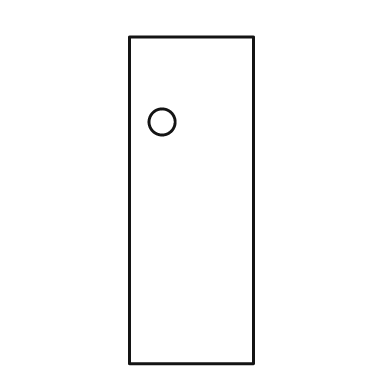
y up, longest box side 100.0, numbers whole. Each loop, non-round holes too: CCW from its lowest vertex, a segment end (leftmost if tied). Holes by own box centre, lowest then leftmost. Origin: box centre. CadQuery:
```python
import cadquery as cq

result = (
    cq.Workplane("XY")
    .moveTo(-19.0, -50.0)
    .lineTo(19.0, -50.0)
    .lineTo(19.0, 50.0)
    .lineTo(-19.0, 50.0)
    .close()
    .moveTo(-9.0, 24.0)
    .circle(4.0)
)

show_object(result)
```